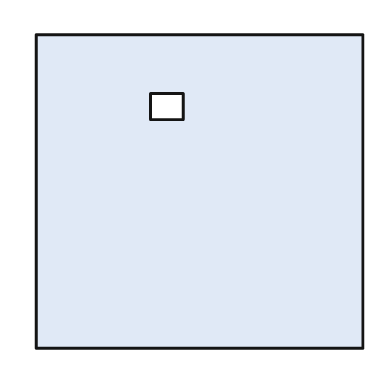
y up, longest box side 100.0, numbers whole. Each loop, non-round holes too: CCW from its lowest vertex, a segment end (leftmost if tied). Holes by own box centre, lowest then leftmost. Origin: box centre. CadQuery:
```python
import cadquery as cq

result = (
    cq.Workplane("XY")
    .moveTo(-50.0, -48.0)
    .lineTo(50.0, -48.0)
    .lineTo(50.0, 48.0)
    .lineTo(-50.0, 48.0)
    .close()
    .moveTo(-15.0, 22.0)
    .lineTo(-5.0, 22.0)
    .lineTo(-5.0, 30.0)
    .lineTo(-15.0, 30.0)
    .close()
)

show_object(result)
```